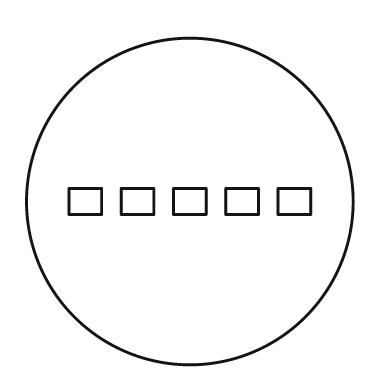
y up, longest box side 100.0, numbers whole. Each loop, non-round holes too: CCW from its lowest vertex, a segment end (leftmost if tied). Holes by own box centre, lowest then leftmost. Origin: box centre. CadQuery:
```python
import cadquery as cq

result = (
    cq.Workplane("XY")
    .moveTo(0.0, 0.0)
    .circle(50.0)
    .moveTo(-37.0, -4.0)
    .lineTo(-27.0, -4.0)
    .lineTo(-27.0, 4.0)
    .lineTo(-37.0, 4.0)
    .close()
    .moveTo(-21.0, -4.0)
    .lineTo(-11.0, -4.0)
    .lineTo(-11.0, 4.0)
    .lineTo(-21.0, 4.0)
    .close()
    .moveTo(-5.0, -4.0)
    .lineTo(5.0, -4.0)
    .lineTo(5.0, 4.0)
    .lineTo(-5.0, 4.0)
    .close()
    .moveTo(11.0, -4.0)
    .lineTo(21.0, -4.0)
    .lineTo(21.0, 4.0)
    .lineTo(11.0, 4.0)
    .close()
    .moveTo(27.0, -4.0)
    .lineTo(37.0, -4.0)
    .lineTo(37.0, 4.0)
    .lineTo(27.0, 4.0)
    .close()
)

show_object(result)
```